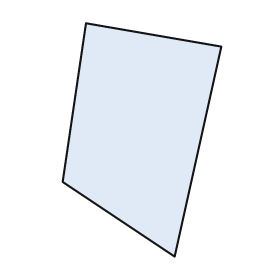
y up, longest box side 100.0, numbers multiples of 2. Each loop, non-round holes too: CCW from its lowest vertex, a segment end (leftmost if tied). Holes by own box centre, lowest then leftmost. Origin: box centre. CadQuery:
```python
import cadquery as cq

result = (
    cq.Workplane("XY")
    .moveTo(14.0, -50.0)
    .lineTo(34.0, 40.0)
    .lineTo(-24.0, 50.0)
    .lineTo(-34.0, -18.0)
    .close()
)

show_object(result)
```